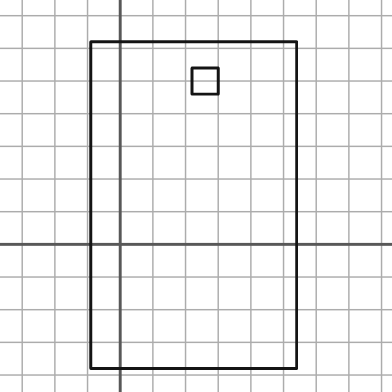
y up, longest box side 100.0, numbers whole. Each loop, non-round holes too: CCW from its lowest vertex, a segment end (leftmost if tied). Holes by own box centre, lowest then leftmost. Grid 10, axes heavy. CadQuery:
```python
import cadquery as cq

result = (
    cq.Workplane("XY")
    .moveTo(-9.0, -38.0)
    .lineTo(54.0, -38.0)
    .lineTo(54.0, 62.0)
    .lineTo(-9.0, 62.0)
    .close()
    .moveTo(22.0, 46.0)
    .lineTo(30.0, 46.0)
    .lineTo(30.0, 54.0)
    .lineTo(22.0, 54.0)
    .close()
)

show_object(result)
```